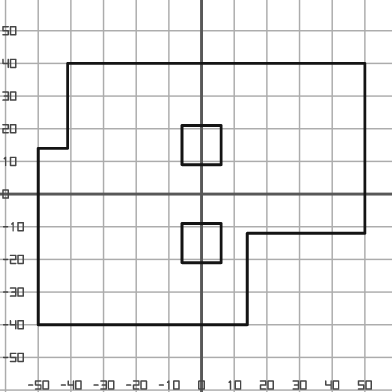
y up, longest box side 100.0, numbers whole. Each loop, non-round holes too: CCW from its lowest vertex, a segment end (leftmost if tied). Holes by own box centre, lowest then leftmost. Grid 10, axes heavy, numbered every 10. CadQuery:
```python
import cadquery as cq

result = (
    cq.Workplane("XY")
    .moveTo(-50.0, -40.0)
    .lineTo(14.0, -40.0)
    .lineTo(14.0, -12.0)
    .lineTo(50.0, -12.0)
    .lineTo(50.0, 40.0)
    .lineTo(-41.0, 40.0)
    .lineTo(-41.0, 14.0)
    .lineTo(-50.0, 14.0)
    .close()
    .moveTo(-6.0, -21.0)
    .lineTo(6.0, -21.0)
    .lineTo(6.0, -9.0)
    .lineTo(-6.0, -9.0)
    .close()
    .moveTo(-6.0, 9.0)
    .lineTo(6.0, 9.0)
    .lineTo(6.0, 21.0)
    .lineTo(-6.0, 21.0)
    .close()
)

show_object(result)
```